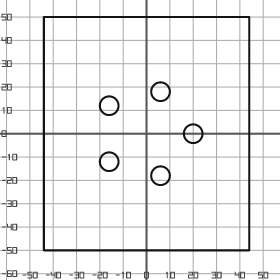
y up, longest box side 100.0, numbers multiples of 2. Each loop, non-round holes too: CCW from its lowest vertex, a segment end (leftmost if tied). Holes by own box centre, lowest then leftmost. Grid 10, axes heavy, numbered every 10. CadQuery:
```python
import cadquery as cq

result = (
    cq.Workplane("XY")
    .moveTo(-44.0, -50.0)
    .lineTo(44.0, -50.0)
    .lineTo(44.0, 50.0)
    .lineTo(-44.0, 50.0)
    .close()
    .moveTo(6.0, -18.0)
    .circle(4.0)
    .moveTo(-16.0, -12.0)
    .circle(4.0)
    .moveTo(20.0, 0.0)
    .circle(4.0)
    .moveTo(-16.0, 12.0)
    .circle(4.0)
    .moveTo(6.0, 18.0)
    .circle(4.0)
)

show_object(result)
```